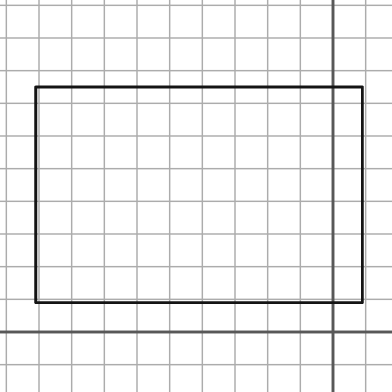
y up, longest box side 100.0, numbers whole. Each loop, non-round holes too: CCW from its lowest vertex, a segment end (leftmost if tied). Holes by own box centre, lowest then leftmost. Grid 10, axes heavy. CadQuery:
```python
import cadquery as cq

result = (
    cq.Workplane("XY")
    .moveTo(-91.0, 9.0)
    .lineTo(9.0, 9.0)
    .lineTo(9.0, 75.0)
    .lineTo(-91.0, 75.0)
    .close()
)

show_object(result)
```